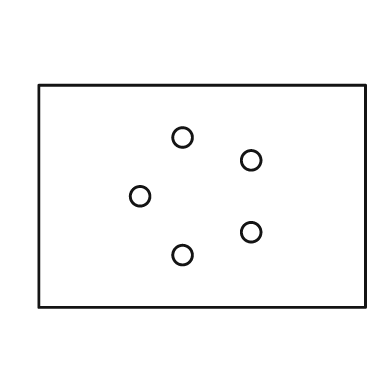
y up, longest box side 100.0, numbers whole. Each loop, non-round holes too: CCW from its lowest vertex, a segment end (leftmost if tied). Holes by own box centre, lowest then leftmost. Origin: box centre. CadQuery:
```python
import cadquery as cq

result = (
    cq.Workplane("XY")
    .moveTo(-50.0, -34.0)
    .lineTo(50.0, -34.0)
    .lineTo(50.0, 34.0)
    .lineTo(-50.0, 34.0)
    .close()
    .moveTo(-6.0, -18.0)
    .circle(3.0)
    .moveTo(15.0, -11.0)
    .circle(3.0)
    .moveTo(-19.0, 0.0)
    .circle(3.0)
    .moveTo(15.0, 11.0)
    .circle(3.0)
    .moveTo(-6.0, 18.0)
    .circle(3.0)
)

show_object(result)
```